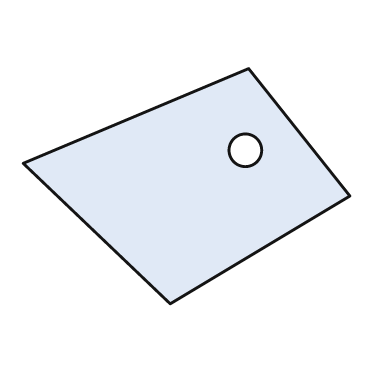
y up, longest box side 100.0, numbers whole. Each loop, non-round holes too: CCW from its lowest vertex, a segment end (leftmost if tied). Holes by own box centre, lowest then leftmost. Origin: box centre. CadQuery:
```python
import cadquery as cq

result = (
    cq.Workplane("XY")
    .moveTo(-5.0, -36.0)
    .lineTo(50.0, -3.0)
    .lineTo(19.0, 36.0)
    .lineTo(-50.0, 7.0)
    .close()
    .moveTo(18.0, 11.0)
    .circle(5.0)
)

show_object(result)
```